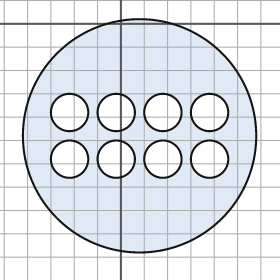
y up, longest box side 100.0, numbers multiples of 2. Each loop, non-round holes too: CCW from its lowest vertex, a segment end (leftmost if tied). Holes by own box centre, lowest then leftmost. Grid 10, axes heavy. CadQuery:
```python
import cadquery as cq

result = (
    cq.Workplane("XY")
    .moveTo(8.0, -48.0)
    .circle(50.0)
    .moveTo(-22.0, -58.0)
    .circle(8.0)
    .moveTo(-2.0, -58.0)
    .circle(8.0)
    .moveTo(18.0, -58.0)
    .circle(8.0)
    .moveTo(38.0, -58.0)
    .circle(8.0)
    .moveTo(-22.0, -38.0)
    .circle(8.0)
    .moveTo(-2.0, -38.0)
    .circle(8.0)
    .moveTo(18.0, -38.0)
    .circle(8.0)
    .moveTo(38.0, -38.0)
    .circle(8.0)
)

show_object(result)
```